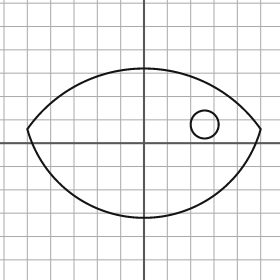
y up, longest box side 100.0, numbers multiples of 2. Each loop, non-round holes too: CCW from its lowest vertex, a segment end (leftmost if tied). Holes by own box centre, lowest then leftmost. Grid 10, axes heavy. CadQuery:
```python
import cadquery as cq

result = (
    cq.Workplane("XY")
    .moveTo(-50.0, 6.0)
    .threePointArc((0.0, -32.0), (50.0, 6.0))
    .threePointArc((0.0, 32.0), (-50.0, 6.0))
    .close()
    .moveTo(26.0, 8.0)
    .circle(6.0)
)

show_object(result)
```